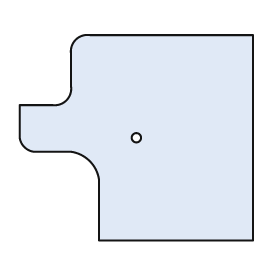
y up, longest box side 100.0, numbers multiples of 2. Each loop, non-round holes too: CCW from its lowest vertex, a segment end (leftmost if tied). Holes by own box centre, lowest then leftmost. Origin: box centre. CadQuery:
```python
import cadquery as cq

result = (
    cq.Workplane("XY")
    .moveTo(-16.0, -44.0)
    .lineTo(50.0, -44.0)
    .lineTo(50.0, 44.0)
    .lineTo(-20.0, 44.0)
    .threePointArc((-26.0, 42.0), (-28.0, 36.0))
    .lineTo(-28.0, 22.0)
    .threePointArc((-30.0, 16.0), (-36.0, 14.0))
    .lineTo(-50.0, 14.0)
    .lineTo(-50.0, 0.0)
    .threePointArc((-48.0, -4.0), (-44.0, -6.0))
    .lineTo(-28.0, -6.0)
    .threePointArc((-20.0, -10.0), (-16.0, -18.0))
    .close()
    .moveTo(0.0, 0.0)
    .circle(2.0)
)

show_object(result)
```